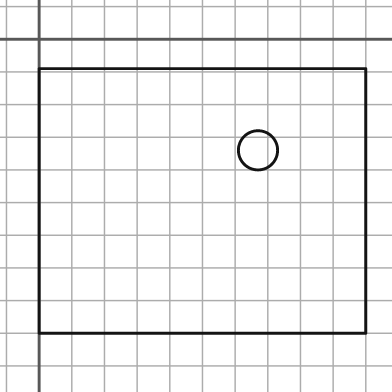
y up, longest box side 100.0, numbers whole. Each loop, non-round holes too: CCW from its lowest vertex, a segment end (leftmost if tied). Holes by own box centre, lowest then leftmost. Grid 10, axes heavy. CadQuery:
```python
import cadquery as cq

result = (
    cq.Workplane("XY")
    .moveTo(0.0, -90.0)
    .lineTo(100.0, -90.0)
    .lineTo(100.0, -9.0)
    .lineTo(0.0, -9.0)
    .close()
    .moveTo(67.0, -34.0)
    .circle(6.0)
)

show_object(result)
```